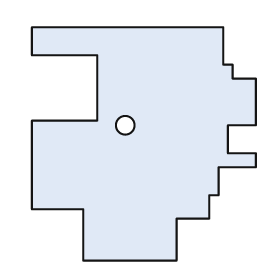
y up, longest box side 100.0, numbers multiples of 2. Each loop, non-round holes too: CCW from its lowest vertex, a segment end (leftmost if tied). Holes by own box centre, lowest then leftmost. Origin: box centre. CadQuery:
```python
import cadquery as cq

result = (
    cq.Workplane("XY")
    .moveTo(-26.0, -50.0)
    .lineTo(14.0, -50.0)
    .lineTo(14.0, -32.0)
    .lineTo(28.0, -32.0)
    .lineTo(28.0, -22.0)
    .lineTo(32.0, -22.0)
    .lineTo(32.0, -10.0)
    .lineTo(48.0, -10.0)
    .lineTo(48.0, -4.0)
    .lineTo(36.0, -4.0)
    .lineTo(36.0, 8.0)
    .lineTo(48.0, 8.0)
    .lineTo(48.0, 28.0)
    .lineTo(38.0, 28.0)
    .lineTo(38.0, 34.0)
    .lineTo(34.0, 34.0)
    .lineTo(34.0, 50.0)
    .lineTo(-48.0, 50.0)
    .lineTo(-48.0, 38.0)
    .lineTo(-20.0, 38.0)
    .lineTo(-20.0, 10.0)
    .lineTo(-48.0, 10.0)
    .lineTo(-48.0, -28.0)
    .lineTo(-26.0, -28.0)
    .close()
    .moveTo(-8.0, 8.0)
    .circle(4.0)
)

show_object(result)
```